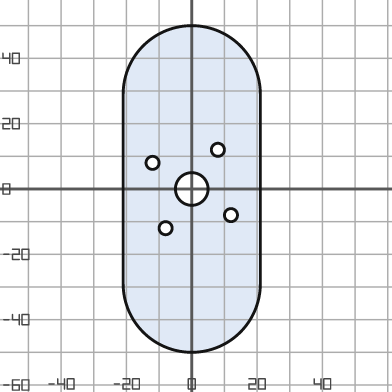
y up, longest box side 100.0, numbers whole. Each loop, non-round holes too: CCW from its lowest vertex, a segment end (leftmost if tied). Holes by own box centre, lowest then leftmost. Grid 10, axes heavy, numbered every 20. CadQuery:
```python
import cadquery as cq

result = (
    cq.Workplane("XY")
    .moveTo(-21.0, -29.0)
    .threePointArc((0.0, -50.0), (21.0, -29.0))
    .lineTo(21.0, 29.0)
    .threePointArc((0.0, 50.0), (-21.0, 29.0))
    .close()
    .moveTo(-8.0, -12.0)
    .circle(2.0)
    .moveTo(12.0, -8.0)
    .circle(2.0)
    .moveTo(0.0, 0.0)
    .circle(5.0)
    .moveTo(-12.0, 8.0)
    .circle(2.0)
    .moveTo(8.0, 12.0)
    .circle(2.0)
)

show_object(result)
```